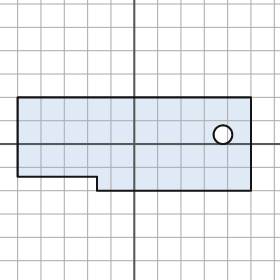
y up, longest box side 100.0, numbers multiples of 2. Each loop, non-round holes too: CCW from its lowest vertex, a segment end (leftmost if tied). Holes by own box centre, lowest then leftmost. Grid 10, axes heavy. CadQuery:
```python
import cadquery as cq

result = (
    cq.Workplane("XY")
    .moveTo(-16.0, -20.0)
    .lineTo(50.0, -20.0)
    .lineTo(50.0, 20.0)
    .lineTo(-50.0, 20.0)
    .lineTo(-50.0, -14.0)
    .lineTo(-16.0, -14.0)
    .close()
    .moveTo(38.0, 4.0)
    .circle(4.0)
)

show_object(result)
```